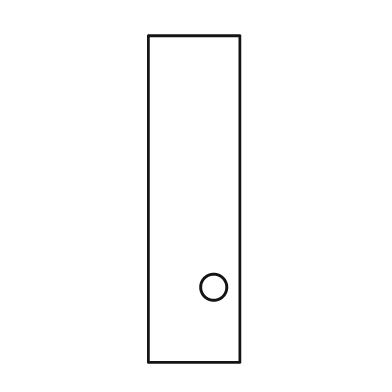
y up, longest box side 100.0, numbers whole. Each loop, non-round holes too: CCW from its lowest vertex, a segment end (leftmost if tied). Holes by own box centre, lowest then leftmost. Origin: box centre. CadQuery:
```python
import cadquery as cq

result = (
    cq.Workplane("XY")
    .moveTo(-14.0, -50.0)
    .lineTo(14.0, -50.0)
    .lineTo(14.0, 50.0)
    .lineTo(-14.0, 50.0)
    .close()
    .moveTo(6.0, -27.0)
    .circle(4.0)
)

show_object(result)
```